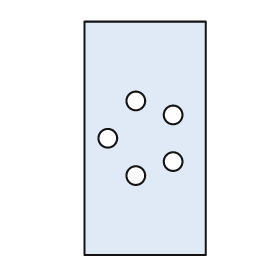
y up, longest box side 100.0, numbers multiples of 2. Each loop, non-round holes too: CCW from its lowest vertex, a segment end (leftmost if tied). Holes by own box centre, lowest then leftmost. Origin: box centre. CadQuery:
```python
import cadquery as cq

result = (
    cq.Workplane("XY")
    .moveTo(-26.0, -50.0)
    .lineTo(26.0, -50.0)
    .lineTo(26.0, 50.0)
    .lineTo(-26.0, 50.0)
    .close()
    .moveTo(-4.0, -16.0)
    .circle(4.0)
    .moveTo(12.0, -10.0)
    .circle(4.0)
    .moveTo(-16.0, 0.0)
    .circle(4.0)
    .moveTo(12.0, 10.0)
    .circle(4.0)
    .moveTo(-4.0, 16.0)
    .circle(4.0)
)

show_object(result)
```